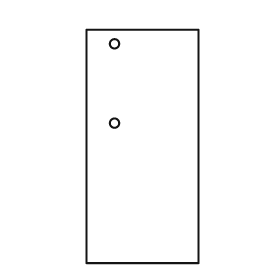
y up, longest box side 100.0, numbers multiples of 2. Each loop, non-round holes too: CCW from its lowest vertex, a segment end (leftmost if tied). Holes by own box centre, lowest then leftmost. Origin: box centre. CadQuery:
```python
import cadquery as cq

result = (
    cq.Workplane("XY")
    .moveTo(-24.0, -50.0)
    .lineTo(24.0, -50.0)
    .lineTo(24.0, 50.0)
    .lineTo(-24.0, 50.0)
    .close()
    .moveTo(-12.0, 10.0)
    .circle(2.0)
    .moveTo(-12.0, 44.0)
    .circle(2.0)
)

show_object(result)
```